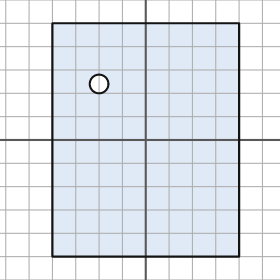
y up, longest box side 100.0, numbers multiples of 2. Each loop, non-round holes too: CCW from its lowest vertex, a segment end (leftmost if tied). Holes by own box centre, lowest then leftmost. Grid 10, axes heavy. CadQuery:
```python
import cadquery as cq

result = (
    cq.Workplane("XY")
    .moveTo(-40.0, -50.0)
    .lineTo(40.0, -50.0)
    .lineTo(40.0, 50.0)
    .lineTo(-40.0, 50.0)
    .close()
    .moveTo(-20.0, 24.0)
    .circle(4.0)
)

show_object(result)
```